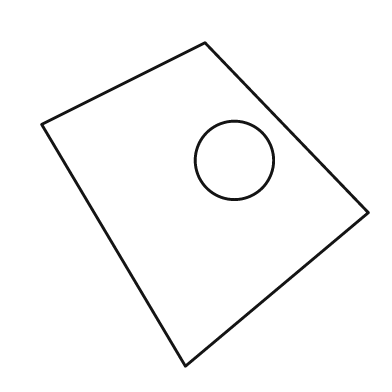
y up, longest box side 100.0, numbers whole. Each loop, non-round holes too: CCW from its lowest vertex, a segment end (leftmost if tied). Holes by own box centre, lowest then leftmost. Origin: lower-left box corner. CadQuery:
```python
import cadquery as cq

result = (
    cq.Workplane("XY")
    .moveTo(44.0, 0.0)
    .lineTo(100.0, 47.0)
    .lineTo(50.0, 99.0)
    .lineTo(0.0, 74.0)
    .close()
    .moveTo(59.0, 63.0)
    .circle(12.0)
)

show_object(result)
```